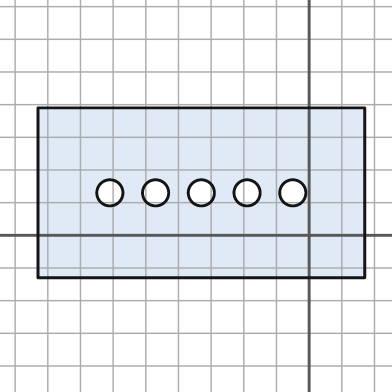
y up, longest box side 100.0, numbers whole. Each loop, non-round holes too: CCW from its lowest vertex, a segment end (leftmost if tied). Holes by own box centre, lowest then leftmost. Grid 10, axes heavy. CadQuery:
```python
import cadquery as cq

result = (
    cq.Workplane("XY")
    .moveTo(-83.0, -13.0)
    .lineTo(17.0, -13.0)
    .lineTo(17.0, 39.0)
    .lineTo(-83.0, 39.0)
    .close()
    .moveTo(-61.0, 13.0)
    .circle(4.0)
    .moveTo(-47.0, 13.0)
    .circle(4.0)
    .moveTo(-33.0, 13.0)
    .circle(4.0)
    .moveTo(-19.0, 13.0)
    .circle(4.0)
    .moveTo(-5.0, 13.0)
    .circle(4.0)
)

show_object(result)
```